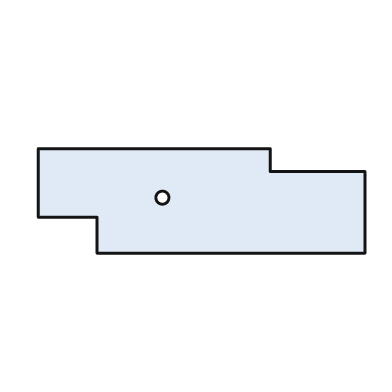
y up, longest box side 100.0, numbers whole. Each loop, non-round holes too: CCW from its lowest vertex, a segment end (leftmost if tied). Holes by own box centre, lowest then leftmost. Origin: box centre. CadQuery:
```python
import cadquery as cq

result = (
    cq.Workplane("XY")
    .moveTo(-32.0, -16.0)
    .lineTo(50.0, -16.0)
    .lineTo(50.0, 9.0)
    .lineTo(21.0, 9.0)
    .lineTo(21.0, 16.0)
    .lineTo(-50.0, 16.0)
    .lineTo(-50.0, -5.0)
    .lineTo(-32.0, -5.0)
    .close()
    .moveTo(-12.0, 1.0)
    .circle(2.0)
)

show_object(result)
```